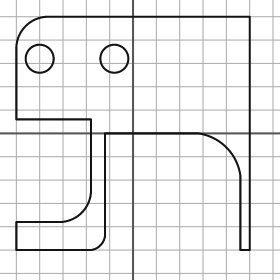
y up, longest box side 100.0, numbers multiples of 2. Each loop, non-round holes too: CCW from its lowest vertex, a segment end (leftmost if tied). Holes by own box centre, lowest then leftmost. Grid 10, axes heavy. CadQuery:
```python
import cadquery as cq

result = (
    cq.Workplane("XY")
    .moveTo(-50.0, -50.0)
    .lineTo(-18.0, -50.0)
    .threePointArc((-14.0, -48.0), (-12.0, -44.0))
    .lineTo(-12.0, 0.0)
    .lineTo(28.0, 0.0)
    .threePointArc((40.0, -6.0), (46.0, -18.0))
    .lineTo(46.0, -50.0)
    .lineTo(50.0, -50.0)
    .lineTo(50.0, 50.0)
    .lineTo(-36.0, 50.0)
    .threePointArc((-46.0, 46.0), (-50.0, 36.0))
    .lineTo(-50.0, 6.0)
    .lineTo(-18.0, 6.0)
    .lineTo(-18.0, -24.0)
    .threePointArc((-22.0, -34.0), (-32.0, -38.0))
    .lineTo(-50.0, -38.0)
    .close()
    .moveTo(-40.0, 32.0)
    .circle(6.0)
    .moveTo(-8.0, 32.0)
    .circle(6.0)
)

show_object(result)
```